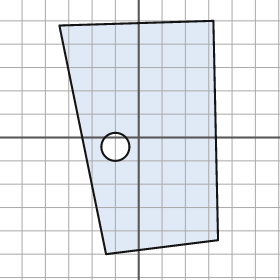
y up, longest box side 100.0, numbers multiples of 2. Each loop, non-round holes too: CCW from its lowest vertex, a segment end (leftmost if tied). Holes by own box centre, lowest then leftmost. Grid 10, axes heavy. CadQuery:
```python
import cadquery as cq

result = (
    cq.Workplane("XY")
    .moveTo(-14.0, -50.0)
    .lineTo(34.0, -44.0)
    .lineTo(32.0, 50.0)
    .lineTo(-34.0, 48.0)
    .close()
    .moveTo(-10.0, -4.0)
    .circle(6.0)
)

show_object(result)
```